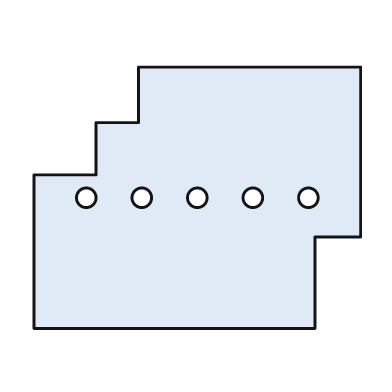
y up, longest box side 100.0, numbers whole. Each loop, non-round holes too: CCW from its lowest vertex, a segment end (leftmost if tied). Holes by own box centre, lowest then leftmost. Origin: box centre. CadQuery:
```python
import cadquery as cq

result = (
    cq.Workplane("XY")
    .moveTo(-50.0, -40.0)
    .lineTo(36.0, -40.0)
    .lineTo(36.0, -12.0)
    .lineTo(50.0, -12.0)
    .lineTo(50.0, 40.0)
    .lineTo(-18.0, 40.0)
    .lineTo(-18.0, 23.0)
    .lineTo(-31.0, 23.0)
    .lineTo(-31.0, 7.0)
    .lineTo(-50.0, 7.0)
    .close()
    .moveTo(-34.0, 0.0)
    .circle(3.0)
    .moveTo(-17.0, 0.0)
    .circle(3.0)
    .moveTo(0.0, 0.0)
    .circle(3.0)
    .moveTo(17.0, 0.0)
    .circle(3.0)
    .moveTo(34.0, 0.0)
    .circle(3.0)
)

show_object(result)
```